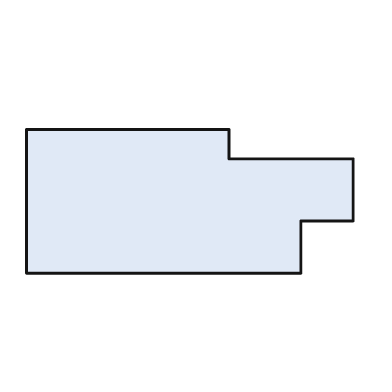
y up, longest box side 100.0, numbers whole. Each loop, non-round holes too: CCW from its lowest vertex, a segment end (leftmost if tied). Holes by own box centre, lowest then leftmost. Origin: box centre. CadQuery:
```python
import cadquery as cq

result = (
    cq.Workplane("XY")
    .moveTo(-50.0, -22.0)
    .lineTo(34.0, -22.0)
    .lineTo(34.0, -6.0)
    .lineTo(50.0, -6.0)
    .lineTo(50.0, 13.0)
    .lineTo(12.0, 13.0)
    .lineTo(12.0, 22.0)
    .lineTo(-50.0, 22.0)
    .close()
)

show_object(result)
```